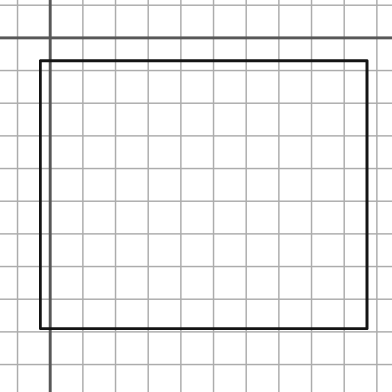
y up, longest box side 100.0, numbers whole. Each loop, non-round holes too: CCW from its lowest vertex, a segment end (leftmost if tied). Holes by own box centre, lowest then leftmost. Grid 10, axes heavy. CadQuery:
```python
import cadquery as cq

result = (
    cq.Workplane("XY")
    .moveTo(-3.0, -89.0)
    .lineTo(97.0, -89.0)
    .lineTo(97.0, -7.0)
    .lineTo(-3.0, -7.0)
    .close()
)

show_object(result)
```